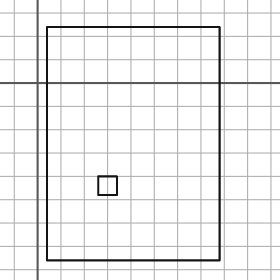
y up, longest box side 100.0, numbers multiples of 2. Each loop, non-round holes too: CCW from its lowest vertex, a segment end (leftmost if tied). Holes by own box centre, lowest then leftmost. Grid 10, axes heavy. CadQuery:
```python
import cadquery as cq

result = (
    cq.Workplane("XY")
    .moveTo(4.0, -76.0)
    .lineTo(78.0, -76.0)
    .lineTo(78.0, 24.0)
    .lineTo(4.0, 24.0)
    .close()
    .moveTo(26.0, -48.0)
    .lineTo(34.0, -48.0)
    .lineTo(34.0, -40.0)
    .lineTo(26.0, -40.0)
    .close()
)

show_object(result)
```